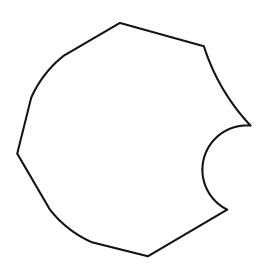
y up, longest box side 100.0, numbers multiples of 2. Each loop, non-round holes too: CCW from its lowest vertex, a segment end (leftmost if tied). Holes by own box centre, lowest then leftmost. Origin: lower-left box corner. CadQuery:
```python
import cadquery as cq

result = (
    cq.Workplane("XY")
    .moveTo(56.0, 0.0)
    .lineTo(90.0, 20.0)
    .threePointArc((80.0, 42.0), (100.0, 56.0))
    .threePointArc((88.0, 72.0), (80.0, 90.0))
    .lineTo(44.0, 100.0)
    .lineTo(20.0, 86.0)
    .threePointArc((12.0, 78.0), (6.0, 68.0))
    .lineTo(0.0, 44.0)
    .lineTo(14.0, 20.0)
    .threePointArc((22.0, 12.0), (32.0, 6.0))
    .close()
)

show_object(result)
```